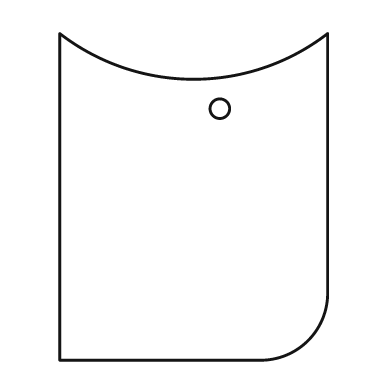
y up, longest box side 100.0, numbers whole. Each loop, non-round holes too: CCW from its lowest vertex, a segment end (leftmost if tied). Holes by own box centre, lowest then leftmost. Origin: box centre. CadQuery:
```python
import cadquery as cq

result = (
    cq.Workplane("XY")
    .moveTo(-41.0, -50.0)
    .lineTo(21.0, -50.0)
    .threePointArc((35.0, -44.0), (41.0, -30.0))
    .lineTo(41.0, 50.0)
    .threePointArc((0.0, 36.0), (-41.0, 50.0))
    .close()
    .moveTo(8.0, 27.0)
    .circle(3.0)
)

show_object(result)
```